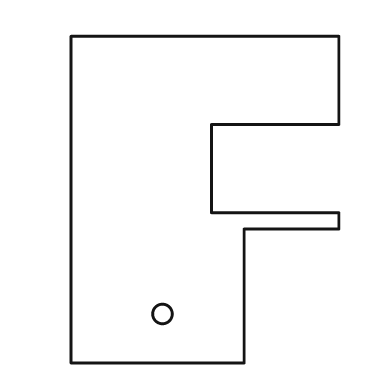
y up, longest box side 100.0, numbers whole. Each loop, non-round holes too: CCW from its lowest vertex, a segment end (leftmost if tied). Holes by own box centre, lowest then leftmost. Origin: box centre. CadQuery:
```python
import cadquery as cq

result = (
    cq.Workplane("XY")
    .moveTo(-41.0, -50.0)
    .lineTo(12.0, -50.0)
    .lineTo(12.0, -9.0)
    .lineTo(41.0, -9.0)
    .lineTo(41.0, -4.0)
    .lineTo(2.0, -4.0)
    .lineTo(2.0, 23.0)
    .lineTo(41.0, 23.0)
    .lineTo(41.0, 50.0)
    .lineTo(-41.0, 50.0)
    .close()
    .moveTo(-13.0, -35.0)
    .circle(3.0)
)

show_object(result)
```